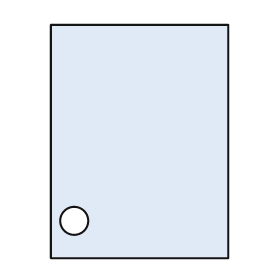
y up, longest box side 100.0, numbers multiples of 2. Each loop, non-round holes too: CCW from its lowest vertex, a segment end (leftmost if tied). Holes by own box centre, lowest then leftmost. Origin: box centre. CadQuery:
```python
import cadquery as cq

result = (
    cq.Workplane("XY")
    .moveTo(-38.0, -50.0)
    .lineTo(38.0, -50.0)
    .lineTo(38.0, 50.0)
    .lineTo(-38.0, 50.0)
    .close()
    .moveTo(-28.0, -34.0)
    .circle(6.0)
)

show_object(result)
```